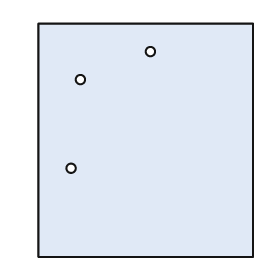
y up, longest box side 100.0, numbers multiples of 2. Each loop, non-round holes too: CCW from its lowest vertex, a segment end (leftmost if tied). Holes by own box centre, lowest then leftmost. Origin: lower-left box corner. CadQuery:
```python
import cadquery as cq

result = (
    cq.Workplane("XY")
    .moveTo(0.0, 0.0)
    .lineTo(92.0, 0.0)
    .lineTo(92.0, 100.0)
    .lineTo(0.0, 100.0)
    .close()
    .moveTo(14.0, 38.0)
    .circle(2.0)
    .moveTo(18.0, 76.0)
    .circle(2.0)
    .moveTo(48.0, 88.0)
    .circle(2.0)
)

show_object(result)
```